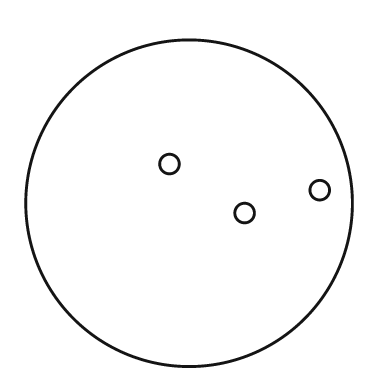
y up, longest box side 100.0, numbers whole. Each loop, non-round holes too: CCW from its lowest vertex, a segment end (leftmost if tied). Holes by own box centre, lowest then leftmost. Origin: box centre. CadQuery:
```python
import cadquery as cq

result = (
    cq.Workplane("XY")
    .moveTo(0.0, 0.0)
    .circle(50.0)
    .moveTo(17.0, -3.0)
    .circle(3.0)
    .moveTo(40.0, 4.0)
    .circle(3.0)
    .moveTo(-6.0, 12.0)
    .circle(3.0)
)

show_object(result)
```